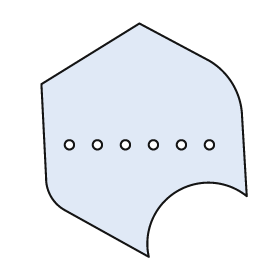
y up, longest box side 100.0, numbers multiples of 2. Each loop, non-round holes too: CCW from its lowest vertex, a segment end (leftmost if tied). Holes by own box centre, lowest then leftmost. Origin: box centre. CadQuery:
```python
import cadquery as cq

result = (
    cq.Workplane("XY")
    .moveTo(2.0, -50.0)
    .threePointArc((14.0, -22.0), (44.0, -24.0))
    .lineTo(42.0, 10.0)
    .threePointArc((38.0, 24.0), (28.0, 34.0))
    .lineTo(-2.0, 50.0)
    .lineTo(-44.0, 24.0)
    .lineTo(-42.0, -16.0)
    .threePointArc((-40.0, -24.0), (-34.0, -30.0))
    .close()
    .moveTo(-32.0, -2.0)
    .circle(2.0)
    .moveTo(-20.0, -2.0)
    .circle(2.0)
    .moveTo(-8.0, -2.0)
    .circle(2.0)
    .moveTo(4.0, -2.0)
    .circle(2.0)
    .moveTo(16.0, -2.0)
    .circle(2.0)
    .moveTo(28.0, -2.0)
    .circle(2.0)
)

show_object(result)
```